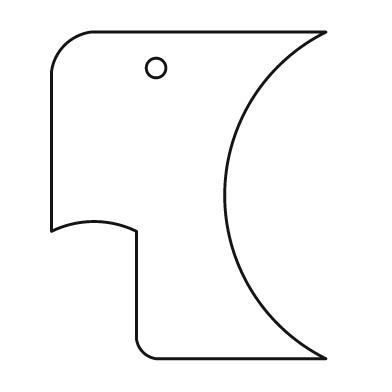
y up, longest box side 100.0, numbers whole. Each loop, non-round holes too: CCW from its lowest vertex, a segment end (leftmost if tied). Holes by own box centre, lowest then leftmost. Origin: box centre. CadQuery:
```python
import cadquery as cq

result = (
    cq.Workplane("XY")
    .moveTo(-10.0, -50.0)
    .lineTo(42.0, -50.0)
    .threePointArc((11.0, 0.0), (42.0, 50.0))
    .lineTo(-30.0, 50.0)
    .threePointArc((-38.0, 46.0), (-42.0, 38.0))
    .lineTo(-42.0, -11.0)
    .threePointArc((-29.0, -8.0), (-16.0, -11.0))
    .lineTo(-16.0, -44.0)
    .threePointArc((-14.0, -48.0), (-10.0, -50.0))
    .close()
    .moveTo(-10.0, 39.0)
    .circle(3.0)
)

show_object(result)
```